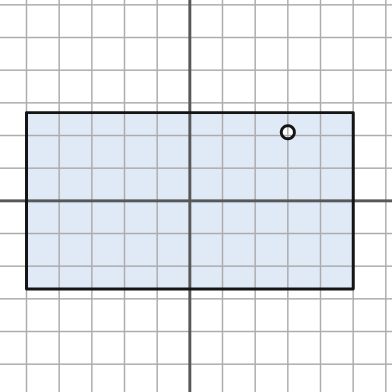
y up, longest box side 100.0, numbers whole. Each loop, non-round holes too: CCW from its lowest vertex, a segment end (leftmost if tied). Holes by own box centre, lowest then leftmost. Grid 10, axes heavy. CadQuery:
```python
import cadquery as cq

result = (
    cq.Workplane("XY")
    .moveTo(-50.0, -27.0)
    .lineTo(50.0, -27.0)
    .lineTo(50.0, 27.0)
    .lineTo(-50.0, 27.0)
    .close()
    .moveTo(30.0, 21.0)
    .circle(2.0)
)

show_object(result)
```